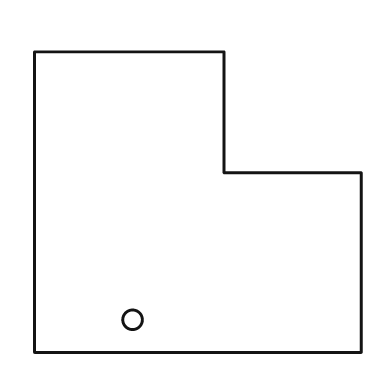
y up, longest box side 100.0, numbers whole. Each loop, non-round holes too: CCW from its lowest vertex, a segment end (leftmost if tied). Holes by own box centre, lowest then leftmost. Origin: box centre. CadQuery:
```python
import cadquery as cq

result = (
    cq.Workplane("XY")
    .moveTo(-50.0, -46.0)
    .lineTo(50.0, -46.0)
    .lineTo(50.0, 9.0)
    .lineTo(8.0, 9.0)
    .lineTo(8.0, 46.0)
    .lineTo(-50.0, 46.0)
    .close()
    .moveTo(-20.0, -36.0)
    .circle(3.0)
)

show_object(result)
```